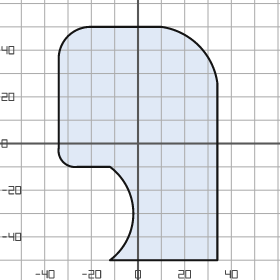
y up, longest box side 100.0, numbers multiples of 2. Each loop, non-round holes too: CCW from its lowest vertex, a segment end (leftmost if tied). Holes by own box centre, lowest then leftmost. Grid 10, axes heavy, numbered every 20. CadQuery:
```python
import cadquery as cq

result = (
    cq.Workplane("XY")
    .moveTo(-12.0, -50.0)
    .lineTo(34.0, -50.0)
    .lineTo(34.0, 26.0)
    .threePointArc((26.0, 42.0), (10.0, 50.0))
    .lineTo(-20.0, 50.0)
    .threePointArc((-30.0, 46.0), (-34.0, 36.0))
    .lineTo(-34.0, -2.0)
    .threePointArc((-32.0, -8.0), (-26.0, -10.0))
    .lineTo(-12.0, -10.0)
    .threePointArc((-2.0, -30.0), (-12.0, -50.0))
    .close()
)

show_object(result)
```